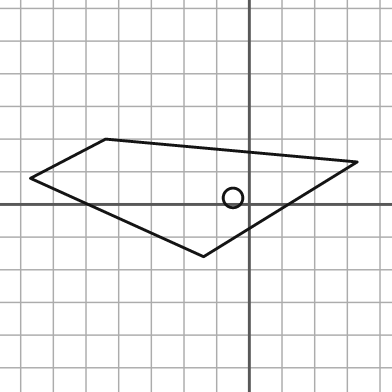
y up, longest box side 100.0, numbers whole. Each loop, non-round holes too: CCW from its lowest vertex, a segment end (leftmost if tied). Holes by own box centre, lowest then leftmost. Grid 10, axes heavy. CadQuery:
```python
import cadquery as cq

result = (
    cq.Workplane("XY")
    .moveTo(-14.0, -16.0)
    .lineTo(33.0, 13.0)
    .lineTo(-44.0, 20.0)
    .lineTo(-67.0, 8.0)
    .close()
    .moveTo(-5.0, 2.0)
    .circle(3.0)
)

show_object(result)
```